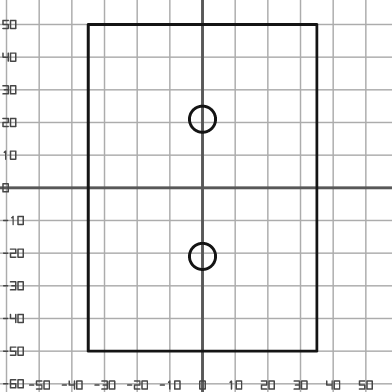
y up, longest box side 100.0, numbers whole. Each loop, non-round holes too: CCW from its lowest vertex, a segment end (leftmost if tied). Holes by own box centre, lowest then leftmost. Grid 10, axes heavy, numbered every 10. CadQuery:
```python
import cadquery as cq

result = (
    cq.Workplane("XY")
    .moveTo(-35.0, -50.0)
    .lineTo(35.0, -50.0)
    .lineTo(35.0, 50.0)
    .lineTo(-35.0, 50.0)
    .close()
    .moveTo(0.0, -21.0)
    .circle(4.0)
    .moveTo(0.0, 21.0)
    .circle(4.0)
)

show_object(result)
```